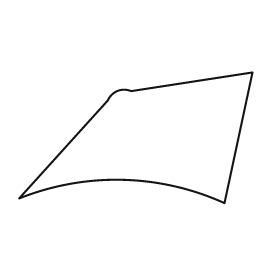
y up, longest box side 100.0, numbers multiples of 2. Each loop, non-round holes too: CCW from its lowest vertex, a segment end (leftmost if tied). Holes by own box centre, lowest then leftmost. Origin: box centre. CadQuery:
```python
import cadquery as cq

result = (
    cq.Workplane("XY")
    .moveTo(38.0, -28.0)
    .lineTo(50.0, 28.0)
    .lineTo(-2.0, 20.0)
    .threePointArc((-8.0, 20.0), (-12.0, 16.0))
    .lineTo(-50.0, -26.0)
    .threePointArc((-6.0, -18.0), (38.0, -28.0))
    .close()
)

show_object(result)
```